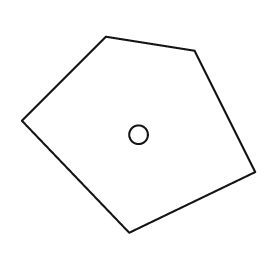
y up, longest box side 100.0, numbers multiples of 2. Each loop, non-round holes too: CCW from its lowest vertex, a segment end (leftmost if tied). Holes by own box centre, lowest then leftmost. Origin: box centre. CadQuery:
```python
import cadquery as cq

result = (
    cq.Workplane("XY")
    .moveTo(-4.0, -42.0)
    .lineTo(50.0, -16.0)
    .lineTo(24.0, 36.0)
    .lineTo(-14.0, 42.0)
    .lineTo(-50.0, 6.0)
    .close()
    .moveTo(0.0, 0.0)
    .circle(4.0)
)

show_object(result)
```